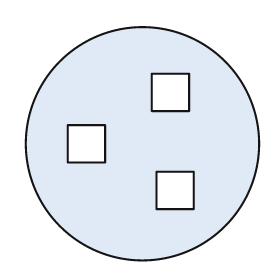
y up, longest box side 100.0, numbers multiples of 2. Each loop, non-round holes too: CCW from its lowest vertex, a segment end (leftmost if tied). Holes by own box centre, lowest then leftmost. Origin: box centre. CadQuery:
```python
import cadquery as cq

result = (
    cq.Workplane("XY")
    .moveTo(0.0, 0.0)
    .circle(50.0)
    .moveTo(6.0, -28.0)
    .lineTo(22.0, -28.0)
    .lineTo(22.0, -12.0)
    .lineTo(6.0, -12.0)
    .close()
    .moveTo(-32.0, -8.0)
    .lineTo(-16.0, -8.0)
    .lineTo(-16.0, 8.0)
    .lineTo(-32.0, 8.0)
    .close()
    .moveTo(4.0, 14.0)
    .lineTo(20.0, 14.0)
    .lineTo(20.0, 30.0)
    .lineTo(4.0, 30.0)
    .close()
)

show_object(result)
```